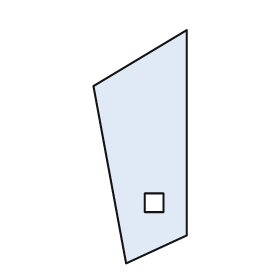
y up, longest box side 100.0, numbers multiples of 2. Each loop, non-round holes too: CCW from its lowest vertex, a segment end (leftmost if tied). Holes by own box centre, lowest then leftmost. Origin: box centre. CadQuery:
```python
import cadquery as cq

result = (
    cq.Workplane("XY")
    .moveTo(-6.0, -50.0)
    .lineTo(20.0, -38.0)
    .lineTo(20.0, 50.0)
    .lineTo(-20.0, 26.0)
    .close()
    .moveTo(2.0, -28.0)
    .lineTo(10.0, -28.0)
    .lineTo(10.0, -20.0)
    .lineTo(2.0, -20.0)
    .close()
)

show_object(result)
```